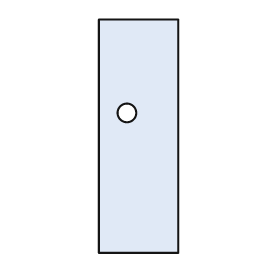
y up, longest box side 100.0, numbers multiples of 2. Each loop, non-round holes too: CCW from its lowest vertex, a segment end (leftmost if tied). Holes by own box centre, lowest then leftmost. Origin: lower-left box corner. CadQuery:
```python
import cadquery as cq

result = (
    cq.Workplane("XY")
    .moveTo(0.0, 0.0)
    .lineTo(34.0, 0.0)
    .lineTo(34.0, 100.0)
    .lineTo(0.0, 100.0)
    .close()
    .moveTo(12.0, 60.0)
    .circle(4.0)
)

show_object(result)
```